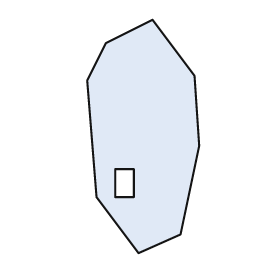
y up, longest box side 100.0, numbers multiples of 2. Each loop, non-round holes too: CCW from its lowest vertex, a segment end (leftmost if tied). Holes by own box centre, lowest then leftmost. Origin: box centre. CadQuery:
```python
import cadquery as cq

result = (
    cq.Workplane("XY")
    .moveTo(-2.0, -50.0)
    .lineTo(16.0, -42.0)
    .lineTo(24.0, -4.0)
    .lineTo(22.0, 26.0)
    .lineTo(4.0, 50.0)
    .lineTo(-16.0, 40.0)
    .lineTo(-24.0, 24.0)
    .lineTo(-20.0, -26.0)
    .close()
    .moveTo(-12.0, -26.0)
    .lineTo(-4.0, -26.0)
    .lineTo(-4.0, -14.0)
    .lineTo(-12.0, -14.0)
    .close()
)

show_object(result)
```